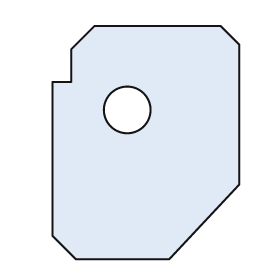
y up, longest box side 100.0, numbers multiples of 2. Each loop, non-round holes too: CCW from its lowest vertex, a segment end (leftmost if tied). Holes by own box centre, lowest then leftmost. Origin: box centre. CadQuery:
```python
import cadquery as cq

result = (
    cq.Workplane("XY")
    .moveTo(-30.0, -50.0)
    .lineTo(10.0, -50.0)
    .lineTo(40.0, -18.0)
    .lineTo(40.0, 42.0)
    .lineTo(32.0, 50.0)
    .lineTo(-22.0, 50.0)
    .lineTo(-32.0, 40.0)
    .lineTo(-32.0, 26.0)
    .lineTo(-40.0, 26.0)
    .lineTo(-40.0, -40.0)
    .close()
    .moveTo(-8.0, 14.0)
    .circle(10.0)
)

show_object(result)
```